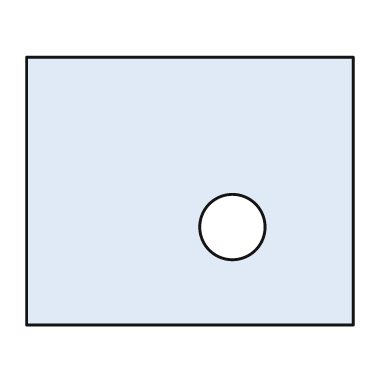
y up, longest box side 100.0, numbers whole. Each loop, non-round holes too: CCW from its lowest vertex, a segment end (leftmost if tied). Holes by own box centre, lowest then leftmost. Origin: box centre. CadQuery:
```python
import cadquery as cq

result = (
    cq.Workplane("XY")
    .moveTo(-50.0, -41.0)
    .lineTo(50.0, -41.0)
    .lineTo(50.0, 41.0)
    .lineTo(-50.0, 41.0)
    .close()
    .moveTo(13.0, -11.0)
    .circle(10.0)
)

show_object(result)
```